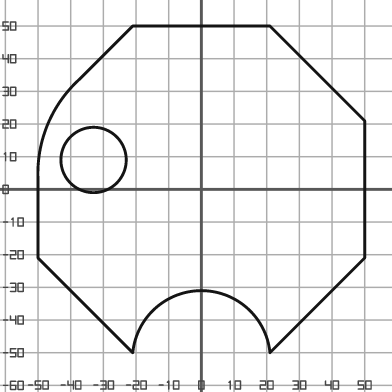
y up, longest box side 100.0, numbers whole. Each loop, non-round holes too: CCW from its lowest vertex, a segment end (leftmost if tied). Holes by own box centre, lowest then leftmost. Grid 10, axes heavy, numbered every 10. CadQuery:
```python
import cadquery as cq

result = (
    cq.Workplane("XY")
    .moveTo(-21.0, -50.0)
    .threePointArc((0.0, -31.0), (21.0, -50.0))
    .lineTo(50.0, -21.0)
    .lineTo(50.0, 21.0)
    .lineTo(21.0, 50.0)
    .lineTo(-21.0, 50.0)
    .lineTo(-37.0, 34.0)
    .threePointArc((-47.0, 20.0), (-50.0, 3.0))
    .lineTo(-50.0, -21.0)
    .close()
    .moveTo(-33.0, 9.0)
    .circle(10.0)
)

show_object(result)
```